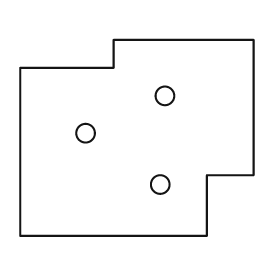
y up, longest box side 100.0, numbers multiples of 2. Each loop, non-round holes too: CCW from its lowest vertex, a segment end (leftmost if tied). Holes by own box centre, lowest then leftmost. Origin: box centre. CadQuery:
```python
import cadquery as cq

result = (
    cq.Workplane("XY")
    .moveTo(-50.0, -42.0)
    .lineTo(30.0, -42.0)
    .lineTo(30.0, -16.0)
    .lineTo(50.0, -16.0)
    .lineTo(50.0, 42.0)
    .lineTo(-10.0, 42.0)
    .lineTo(-10.0, 30.0)
    .lineTo(-50.0, 30.0)
    .close()
    .moveTo(10.0, -20.0)
    .circle(4.0)
    .moveTo(-22.0, 2.0)
    .circle(4.0)
    .moveTo(12.0, 18.0)
    .circle(4.0)
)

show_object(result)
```